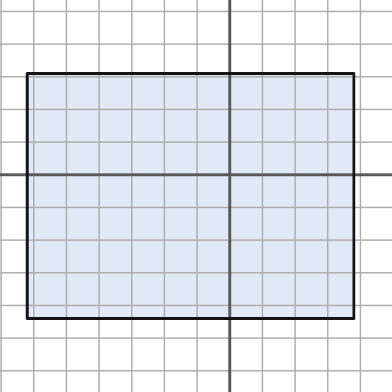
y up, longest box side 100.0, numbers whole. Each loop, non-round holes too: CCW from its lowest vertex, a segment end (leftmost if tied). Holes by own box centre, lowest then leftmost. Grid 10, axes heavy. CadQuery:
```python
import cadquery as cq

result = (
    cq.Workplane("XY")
    .moveTo(-62.0, -44.0)
    .lineTo(38.0, -44.0)
    .lineTo(38.0, 31.0)
    .lineTo(-62.0, 31.0)
    .close()
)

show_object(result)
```